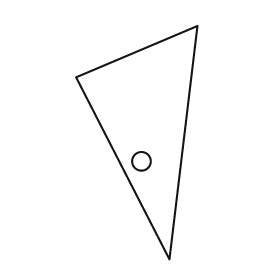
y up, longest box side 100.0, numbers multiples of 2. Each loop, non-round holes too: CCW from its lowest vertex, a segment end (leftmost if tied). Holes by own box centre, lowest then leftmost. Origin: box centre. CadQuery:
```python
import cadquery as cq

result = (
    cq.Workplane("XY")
    .moveTo(14.0, -50.0)
    .lineTo(26.0, 50.0)
    .lineTo(-26.0, 28.0)
    .close()
    .moveTo(2.0, -8.0)
    .circle(4.0)
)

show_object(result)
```